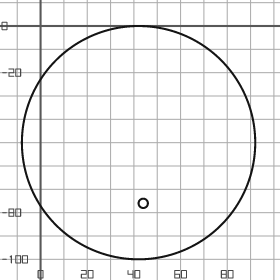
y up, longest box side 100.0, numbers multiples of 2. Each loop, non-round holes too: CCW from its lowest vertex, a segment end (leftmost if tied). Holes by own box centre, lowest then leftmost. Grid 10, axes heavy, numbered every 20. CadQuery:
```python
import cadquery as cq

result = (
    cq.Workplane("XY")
    .moveTo(42.0, -50.0)
    .circle(50.0)
    .moveTo(44.0, -76.0)
    .circle(2.0)
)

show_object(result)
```